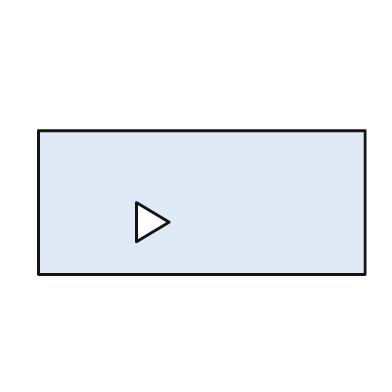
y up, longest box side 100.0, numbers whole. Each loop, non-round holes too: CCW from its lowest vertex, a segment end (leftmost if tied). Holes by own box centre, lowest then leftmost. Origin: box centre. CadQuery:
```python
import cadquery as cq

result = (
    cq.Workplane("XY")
    .moveTo(-50.0, -22.0)
    .lineTo(50.0, -22.0)
    .lineTo(50.0, 22.0)
    .lineTo(-50.0, 22.0)
    .close()
    .moveTo(-20.0, -12.0)
    .lineTo(-10.0, -6.0)
    .lineTo(-20.0, 0.0)
    .close()
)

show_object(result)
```